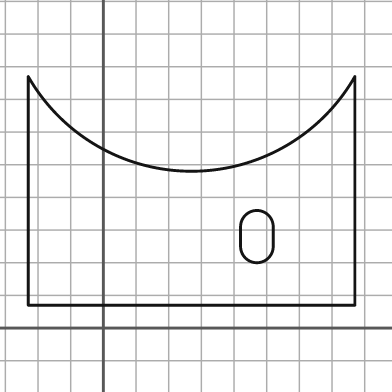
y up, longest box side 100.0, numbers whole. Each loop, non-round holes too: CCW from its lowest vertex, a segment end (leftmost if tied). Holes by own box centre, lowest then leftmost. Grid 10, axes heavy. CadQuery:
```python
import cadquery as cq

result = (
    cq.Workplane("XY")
    .moveTo(-23.0, 7.0)
    .lineTo(77.0, 7.0)
    .lineTo(77.0, 77.0)
    .threePointArc((27.0, 48.0), (-23.0, 77.0))
    .close()
    .moveTo(42.0, 25.0)
    .threePointArc((47.0, 20.0), (52.0, 25.0))
    .lineTo(52.0, 31.0)
    .threePointArc((47.0, 36.0), (42.0, 31.0))
    .close()
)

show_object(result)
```